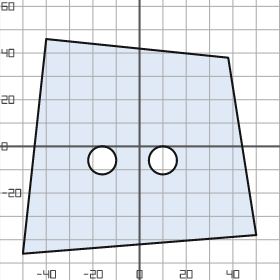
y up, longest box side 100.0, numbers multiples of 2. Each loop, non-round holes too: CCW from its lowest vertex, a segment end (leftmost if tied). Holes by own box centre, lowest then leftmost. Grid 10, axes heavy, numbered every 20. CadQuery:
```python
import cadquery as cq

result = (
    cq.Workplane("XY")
    .moveTo(-50.0, -46.0)
    .lineTo(50.0, -38.0)
    .lineTo(38.0, 38.0)
    .lineTo(-40.0, 46.0)
    .close()
    .moveTo(-16.0, -6.0)
    .circle(6.0)
    .moveTo(10.0, -6.0)
    .circle(6.0)
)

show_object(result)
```